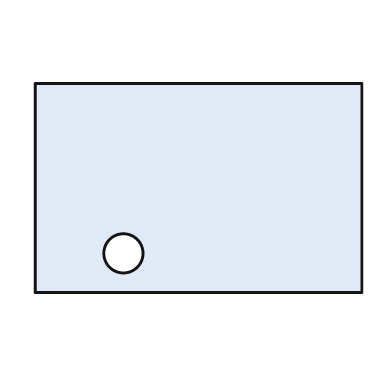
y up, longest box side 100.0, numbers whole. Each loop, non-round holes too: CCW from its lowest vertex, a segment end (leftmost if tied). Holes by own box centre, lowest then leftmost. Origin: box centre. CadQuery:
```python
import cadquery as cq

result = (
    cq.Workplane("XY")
    .moveTo(-50.0, -32.0)
    .lineTo(50.0, -32.0)
    .lineTo(50.0, 32.0)
    .lineTo(-50.0, 32.0)
    .close()
    .moveTo(-23.0, -20.0)
    .circle(6.0)
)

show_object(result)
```